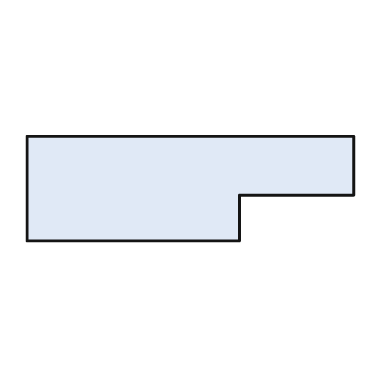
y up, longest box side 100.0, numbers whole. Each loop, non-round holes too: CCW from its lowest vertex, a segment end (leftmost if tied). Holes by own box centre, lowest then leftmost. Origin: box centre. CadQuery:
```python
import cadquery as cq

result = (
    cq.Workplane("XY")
    .moveTo(-50.0, -16.0)
    .lineTo(15.0, -16.0)
    .lineTo(15.0, -2.0)
    .lineTo(50.0, -2.0)
    .lineTo(50.0, 16.0)
    .lineTo(-50.0, 16.0)
    .close()
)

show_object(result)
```